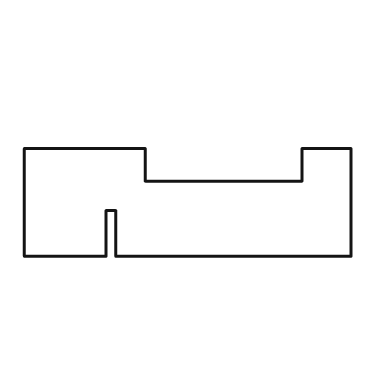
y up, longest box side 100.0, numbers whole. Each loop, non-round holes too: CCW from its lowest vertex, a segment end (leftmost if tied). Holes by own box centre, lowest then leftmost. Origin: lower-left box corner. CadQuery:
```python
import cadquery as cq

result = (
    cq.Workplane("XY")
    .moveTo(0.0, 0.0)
    .lineTo(25.0, 0.0)
    .lineTo(25.0, 14.0)
    .lineTo(28.0, 14.0)
    .lineTo(28.0, 0.0)
    .lineTo(100.0, 0.0)
    .lineTo(100.0, 33.0)
    .lineTo(85.0, 33.0)
    .lineTo(85.0, 23.0)
    .lineTo(37.0, 23.0)
    .lineTo(37.0, 33.0)
    .lineTo(0.0, 33.0)
    .close()
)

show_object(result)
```